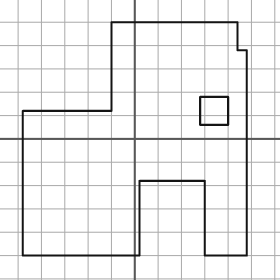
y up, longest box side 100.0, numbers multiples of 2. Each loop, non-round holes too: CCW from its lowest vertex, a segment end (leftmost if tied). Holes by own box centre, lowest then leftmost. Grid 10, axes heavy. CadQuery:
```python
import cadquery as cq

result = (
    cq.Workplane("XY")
    .moveTo(-48.0, -50.0)
    .lineTo(2.0, -50.0)
    .lineTo(2.0, -18.0)
    .lineTo(30.0, -18.0)
    .lineTo(30.0, -50.0)
    .lineTo(48.0, -50.0)
    .lineTo(48.0, 38.0)
    .lineTo(44.0, 38.0)
    .lineTo(44.0, 50.0)
    .lineTo(-10.0, 50.0)
    .lineTo(-10.0, 12.0)
    .lineTo(-48.0, 12.0)
    .close()
    .moveTo(28.0, 6.0)
    .lineTo(40.0, 6.0)
    .lineTo(40.0, 18.0)
    .lineTo(28.0, 18.0)
    .close()
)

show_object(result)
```